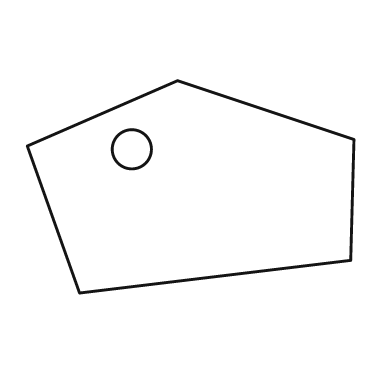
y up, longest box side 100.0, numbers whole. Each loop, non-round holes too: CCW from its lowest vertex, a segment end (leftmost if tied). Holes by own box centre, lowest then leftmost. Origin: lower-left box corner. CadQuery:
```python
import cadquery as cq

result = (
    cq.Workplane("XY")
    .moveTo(16.0, 0.0)
    .lineTo(99.0, 10.0)
    .lineTo(100.0, 47.0)
    .lineTo(46.0, 65.0)
    .lineTo(0.0, 45.0)
    .close()
    .moveTo(32.0, 44.0)
    .circle(6.0)
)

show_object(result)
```